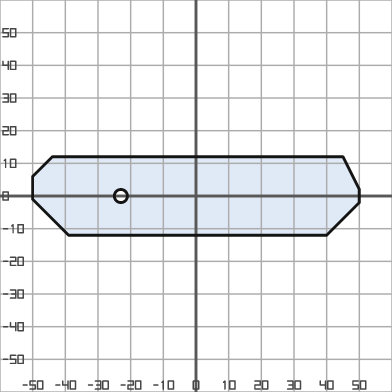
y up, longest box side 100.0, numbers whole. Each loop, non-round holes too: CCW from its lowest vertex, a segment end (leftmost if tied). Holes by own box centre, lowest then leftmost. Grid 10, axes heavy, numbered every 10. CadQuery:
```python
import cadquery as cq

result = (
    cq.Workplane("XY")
    .moveTo(-39.0, -12.0)
    .lineTo(40.0, -12.0)
    .lineTo(50.0, -2.0)
    .lineTo(50.0, 2.0)
    .lineTo(45.0, 12.0)
    .lineTo(-44.0, 12.0)
    .lineTo(-50.0, 6.0)
    .lineTo(-50.0, -1.0)
    .close()
    .moveTo(-23.0, 0.0)
    .circle(2.0)
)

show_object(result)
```